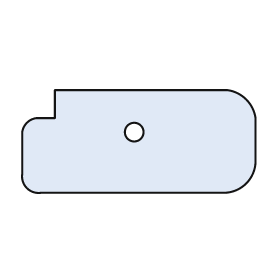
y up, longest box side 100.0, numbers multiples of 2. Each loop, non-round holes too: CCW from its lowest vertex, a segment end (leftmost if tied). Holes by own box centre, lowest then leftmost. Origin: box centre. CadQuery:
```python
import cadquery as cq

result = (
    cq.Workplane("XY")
    .moveTo(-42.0, -22.0)
    .lineTo(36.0, -22.0)
    .threePointArc((46.0, -18.0), (50.0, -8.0))
    .lineTo(50.0, 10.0)
    .threePointArc((46.0, 18.0), (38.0, 22.0))
    .lineTo(-36.0, 22.0)
    .lineTo(-36.0, 10.0)
    .lineTo(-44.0, 10.0)
    .threePointArc((-48.0, 8.0), (-50.0, 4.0))
    .lineTo(-50.0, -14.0)
    .threePointArc((-48.0, -20.0), (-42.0, -22.0))
    .close()
    .moveTo(-2.0, 4.0)
    .circle(4.0)
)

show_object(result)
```